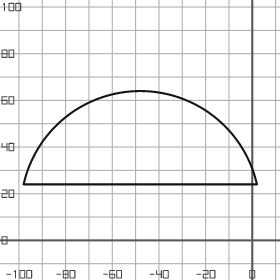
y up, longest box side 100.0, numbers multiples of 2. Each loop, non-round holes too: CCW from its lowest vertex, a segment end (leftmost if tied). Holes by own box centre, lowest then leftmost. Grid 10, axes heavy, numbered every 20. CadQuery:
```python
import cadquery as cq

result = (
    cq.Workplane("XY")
    .moveTo(-98.0, 24.0)
    .lineTo(2.0, 24.0)
    .threePointArc((-48.0, 64.0), (-98.0, 24.0))
    .close()
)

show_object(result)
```